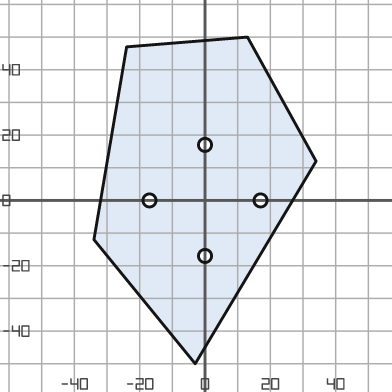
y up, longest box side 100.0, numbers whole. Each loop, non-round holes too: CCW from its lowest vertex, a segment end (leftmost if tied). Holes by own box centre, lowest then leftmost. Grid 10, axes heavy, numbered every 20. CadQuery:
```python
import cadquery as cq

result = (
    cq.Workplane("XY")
    .moveTo(-3.0, -50.0)
    .lineTo(34.0, 12.0)
    .lineTo(13.0, 50.0)
    .lineTo(-24.0, 47.0)
    .lineTo(-34.0, -12.0)
    .close()
    .moveTo(0.0, -17.0)
    .circle(2.0)
    .moveTo(-17.0, 0.0)
    .circle(2.0)
    .moveTo(17.0, 0.0)
    .circle(2.0)
    .moveTo(0.0, 17.0)
    .circle(2.0)
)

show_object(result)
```